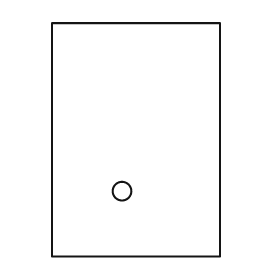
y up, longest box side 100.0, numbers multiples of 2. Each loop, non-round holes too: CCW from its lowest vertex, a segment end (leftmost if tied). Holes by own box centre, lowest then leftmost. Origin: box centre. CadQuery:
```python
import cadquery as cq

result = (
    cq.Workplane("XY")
    .moveTo(-36.0, -50.0)
    .lineTo(36.0, -50.0)
    .lineTo(36.0, 50.0)
    .lineTo(-36.0, 50.0)
    .close()
    .moveTo(-6.0, -22.0)
    .circle(4.0)
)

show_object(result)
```